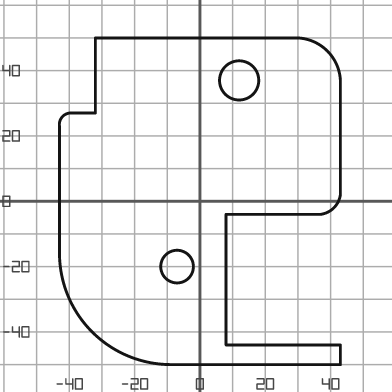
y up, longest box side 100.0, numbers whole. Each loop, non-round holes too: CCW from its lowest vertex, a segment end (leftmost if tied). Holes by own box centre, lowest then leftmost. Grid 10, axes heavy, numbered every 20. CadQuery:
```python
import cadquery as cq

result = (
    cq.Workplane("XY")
    .moveTo(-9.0, -50.0)
    .lineTo(43.0, -50.0)
    .lineTo(43.0, -44.0)
    .lineTo(8.0, -44.0)
    .lineTo(8.0, -4.0)
    .lineTo(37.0, -4.0)
    .threePointArc((41.0, -2.0), (43.0, 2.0))
    .lineTo(43.0, 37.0)
    .threePointArc((39.0, 46.0), (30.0, 50.0))
    .lineTo(-32.0, 50.0)
    .lineTo(-32.0, 27.0)
    .lineTo(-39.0, 27.0)
    .threePointArc((-42.0, 26.0), (-43.0, 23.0))
    .lineTo(-43.0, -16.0)
    .threePointArc((-33.0, -40.0), (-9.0, -50.0))
    .close()
    .moveTo(-7.0, -20.0)
    .circle(5.0)
    .moveTo(12.0, 37.0)
    .circle(6.0)
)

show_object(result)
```